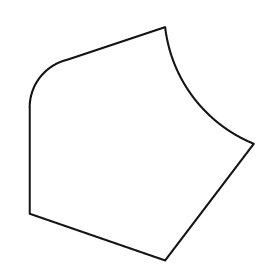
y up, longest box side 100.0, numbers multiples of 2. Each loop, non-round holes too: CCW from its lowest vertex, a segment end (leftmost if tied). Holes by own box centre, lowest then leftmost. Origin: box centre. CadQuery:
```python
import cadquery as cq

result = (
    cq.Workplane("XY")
    .moveTo(10.0, -50.0)
    .lineTo(48.0, 0.0)
    .threePointArc((22.0, 20.0), (10.0, 50.0))
    .lineTo(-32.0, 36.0)
    .threePointArc((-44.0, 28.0), (-48.0, 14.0))
    .lineTo(-48.0, -30.0)
    .close()
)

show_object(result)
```